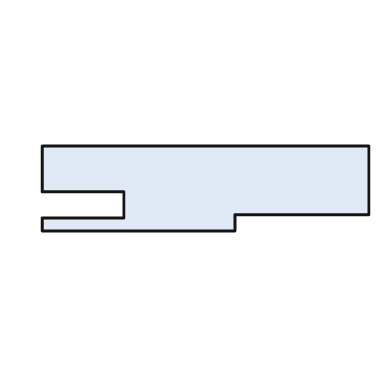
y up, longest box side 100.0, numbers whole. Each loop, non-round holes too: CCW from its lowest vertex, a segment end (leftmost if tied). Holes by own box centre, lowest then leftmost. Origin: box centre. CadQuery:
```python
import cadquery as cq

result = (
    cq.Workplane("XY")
    .moveTo(-50.0, -13.0)
    .lineTo(9.0, -13.0)
    .lineTo(9.0, -8.0)
    .lineTo(50.0, -8.0)
    .lineTo(50.0, 13.0)
    .lineTo(-50.0, 13.0)
    .lineTo(-50.0, -1.0)
    .lineTo(-25.0, -1.0)
    .lineTo(-25.0, -9.0)
    .lineTo(-50.0, -9.0)
    .close()
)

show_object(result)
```